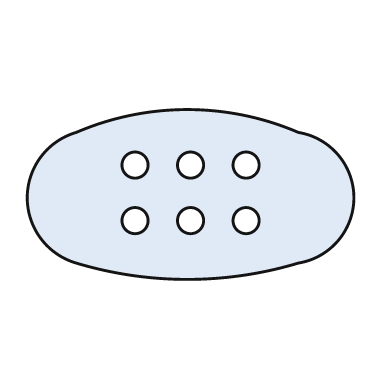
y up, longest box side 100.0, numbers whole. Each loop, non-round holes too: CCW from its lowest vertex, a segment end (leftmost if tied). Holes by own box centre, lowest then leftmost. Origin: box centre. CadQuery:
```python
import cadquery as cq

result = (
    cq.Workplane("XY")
    .moveTo(-35.0, -21.0)
    .threePointArc((-1.0, -26.0), (33.0, -21.0))
    .threePointArc((50.0, -1.0), (33.0, 19.0))
    .threePointArc((-1.0, 26.0), (-35.0, 19.0))
    .threePointArc((-50.0, -1.0), (-35.0, -21.0))
    .close()
    .moveTo(-17.0, -8.0)
    .circle(4.0)
    .moveTo(0.0, -8.0)
    .circle(4.0)
    .moveTo(17.0, -8.0)
    .circle(4.0)
    .moveTo(-17.0, 9.0)
    .circle(4.0)
    .moveTo(0.0, 9.0)
    .circle(4.0)
    .moveTo(17.0, 9.0)
    .circle(4.0)
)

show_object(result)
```